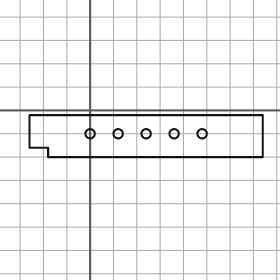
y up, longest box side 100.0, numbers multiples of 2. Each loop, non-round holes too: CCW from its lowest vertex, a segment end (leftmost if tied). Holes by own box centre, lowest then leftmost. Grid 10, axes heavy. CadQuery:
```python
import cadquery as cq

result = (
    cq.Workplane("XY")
    .moveTo(-18.0, -20.0)
    .lineTo(74.0, -20.0)
    .lineTo(74.0, -2.0)
    .lineTo(-26.0, -2.0)
    .lineTo(-26.0, -16.0)
    .lineTo(-18.0, -16.0)
    .close()
    .moveTo(0.0, -10.0)
    .circle(2.0)
    .moveTo(12.0, -10.0)
    .circle(2.0)
    .moveTo(24.0, -10.0)
    .circle(2.0)
    .moveTo(36.0, -10.0)
    .circle(2.0)
    .moveTo(48.0, -10.0)
    .circle(2.0)
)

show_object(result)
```